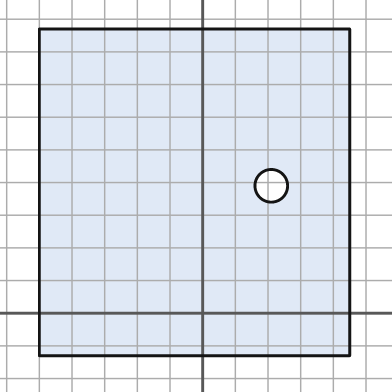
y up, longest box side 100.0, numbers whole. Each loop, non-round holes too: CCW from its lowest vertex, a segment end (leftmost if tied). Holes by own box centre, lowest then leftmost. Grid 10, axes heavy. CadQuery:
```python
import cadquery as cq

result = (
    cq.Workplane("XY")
    .moveTo(-50.0, -13.0)
    .lineTo(45.0, -13.0)
    .lineTo(45.0, 87.0)
    .lineTo(-50.0, 87.0)
    .close()
    .moveTo(21.0, 39.0)
    .circle(5.0)
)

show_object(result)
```